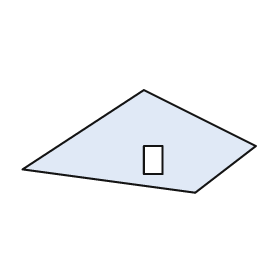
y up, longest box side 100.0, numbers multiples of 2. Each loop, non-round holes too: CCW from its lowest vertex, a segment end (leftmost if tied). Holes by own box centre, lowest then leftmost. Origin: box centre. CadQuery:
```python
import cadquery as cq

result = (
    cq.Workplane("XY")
    .moveTo(24.0, -22.0)
    .lineTo(50.0, -2.0)
    .lineTo(2.0, 22.0)
    .lineTo(-50.0, -12.0)
    .close()
    .moveTo(2.0, -14.0)
    .lineTo(10.0, -14.0)
    .lineTo(10.0, -2.0)
    .lineTo(2.0, -2.0)
    .close()
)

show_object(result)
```